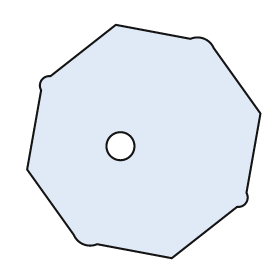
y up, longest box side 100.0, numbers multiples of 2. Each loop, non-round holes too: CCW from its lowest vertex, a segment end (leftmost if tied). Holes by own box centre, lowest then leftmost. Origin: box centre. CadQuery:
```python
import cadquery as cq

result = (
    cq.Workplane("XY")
    .moveTo(12.0, -50.0)
    .lineTo(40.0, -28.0)
    .threePointArc((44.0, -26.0), (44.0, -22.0))
    .lineTo(50.0, 12.0)
    .lineTo(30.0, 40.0)
    .threePointArc((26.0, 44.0), (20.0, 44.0))
    .lineTo(-12.0, 50.0)
    .lineTo(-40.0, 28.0)
    .threePointArc((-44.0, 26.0), (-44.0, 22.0))
    .lineTo(-50.0, -12.0)
    .lineTo(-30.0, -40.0)
    .threePointArc((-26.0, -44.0), (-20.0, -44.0))
    .close()
    .moveTo(-10.0, -2.0)
    .circle(6.0)
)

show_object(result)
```